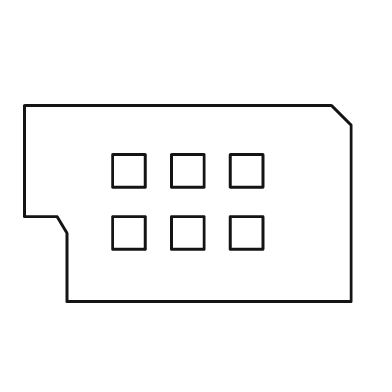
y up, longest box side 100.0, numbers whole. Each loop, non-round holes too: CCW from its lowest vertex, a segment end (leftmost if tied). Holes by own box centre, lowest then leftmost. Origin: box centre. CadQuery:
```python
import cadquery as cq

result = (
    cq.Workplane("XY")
    .moveTo(-37.0, -30.0)
    .lineTo(50.0, -30.0)
    .lineTo(50.0, 24.0)
    .lineTo(44.0, 30.0)
    .lineTo(-50.0, 30.0)
    .lineTo(-50.0, -4.0)
    .lineTo(-40.0, -4.0)
    .lineTo(-37.0, -9.0)
    .close()
    .moveTo(-23.0, -14.0)
    .lineTo(-13.0, -14.0)
    .lineTo(-13.0, -4.0)
    .lineTo(-23.0, -4.0)
    .close()
    .moveTo(-5.0, -14.0)
    .lineTo(5.0, -14.0)
    .lineTo(5.0, -4.0)
    .lineTo(-5.0, -4.0)
    .close()
    .moveTo(13.0, -14.0)
    .lineTo(23.0, -14.0)
    .lineTo(23.0, -4.0)
    .lineTo(13.0, -4.0)
    .close()
    .moveTo(-23.0, 5.0)
    .lineTo(-13.0, 5.0)
    .lineTo(-13.0, 15.0)
    .lineTo(-23.0, 15.0)
    .close()
    .moveTo(-5.0, 5.0)
    .lineTo(5.0, 5.0)
    .lineTo(5.0, 15.0)
    .lineTo(-5.0, 15.0)
    .close()
    .moveTo(13.0, 5.0)
    .lineTo(23.0, 5.0)
    .lineTo(23.0, 15.0)
    .lineTo(13.0, 15.0)
    .close()
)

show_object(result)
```